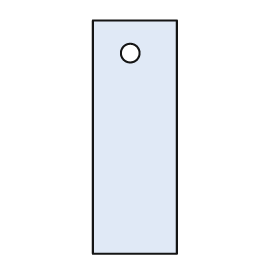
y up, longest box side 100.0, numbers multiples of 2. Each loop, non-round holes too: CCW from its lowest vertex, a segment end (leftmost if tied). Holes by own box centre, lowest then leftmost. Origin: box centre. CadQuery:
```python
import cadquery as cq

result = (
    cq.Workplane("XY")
    .moveTo(-18.0, -50.0)
    .lineTo(18.0, -50.0)
    .lineTo(18.0, 50.0)
    .lineTo(-18.0, 50.0)
    .close()
    .moveTo(-2.0, 36.0)
    .circle(4.0)
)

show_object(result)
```